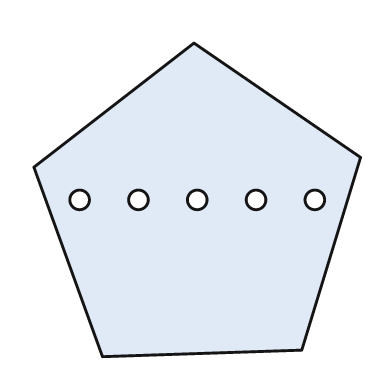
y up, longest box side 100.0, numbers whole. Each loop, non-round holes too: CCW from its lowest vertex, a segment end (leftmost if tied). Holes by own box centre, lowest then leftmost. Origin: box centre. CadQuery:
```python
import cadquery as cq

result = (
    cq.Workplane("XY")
    .moveTo(-29.0, -48.0)
    .lineTo(32.0, -46.0)
    .lineTo(50.0, 13.0)
    .lineTo(-1.0, 48.0)
    .lineTo(-50.0, 10.0)
    .close()
    .moveTo(-36.0, 0.0)
    .circle(3.0)
    .moveTo(-18.0, 0.0)
    .circle(3.0)
    .moveTo(0.0, 0.0)
    .circle(3.0)
    .moveTo(18.0, 0.0)
    .circle(3.0)
    .moveTo(36.0, 0.0)
    .circle(3.0)
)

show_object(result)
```